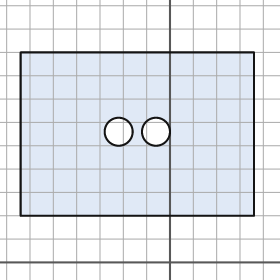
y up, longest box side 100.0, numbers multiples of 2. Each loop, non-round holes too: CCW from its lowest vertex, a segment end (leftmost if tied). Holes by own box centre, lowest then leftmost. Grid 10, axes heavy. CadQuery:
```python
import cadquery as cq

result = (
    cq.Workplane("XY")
    .moveTo(-64.0, 20.0)
    .lineTo(36.0, 20.0)
    .lineTo(36.0, 90.0)
    .lineTo(-64.0, 90.0)
    .close()
    .moveTo(-22.0, 56.0)
    .circle(6.0)
    .moveTo(-6.0, 56.0)
    .circle(6.0)
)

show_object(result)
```